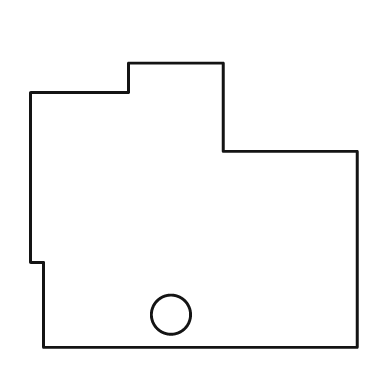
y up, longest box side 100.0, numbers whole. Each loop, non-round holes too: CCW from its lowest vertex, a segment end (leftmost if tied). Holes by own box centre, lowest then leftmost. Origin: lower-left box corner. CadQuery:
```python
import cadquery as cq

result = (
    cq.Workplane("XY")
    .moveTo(4.0, 0.0)
    .lineTo(100.0, 0.0)
    .lineTo(100.0, 60.0)
    .lineTo(59.0, 60.0)
    .lineTo(59.0, 87.0)
    .lineTo(30.0, 87.0)
    .lineTo(30.0, 78.0)
    .lineTo(0.0, 78.0)
    .lineTo(0.0, 26.0)
    .lineTo(4.0, 26.0)
    .close()
    .moveTo(43.0, 10.0)
    .circle(6.0)
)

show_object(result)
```